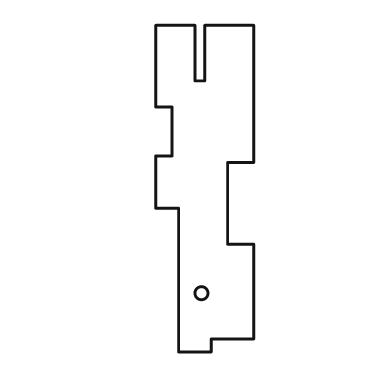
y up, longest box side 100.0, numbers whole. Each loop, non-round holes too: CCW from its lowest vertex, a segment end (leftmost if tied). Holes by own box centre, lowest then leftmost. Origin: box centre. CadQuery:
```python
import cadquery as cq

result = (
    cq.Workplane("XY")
    .moveTo(-8.0, -50.0)
    .lineTo(2.0, -50.0)
    .lineTo(2.0, -46.0)
    .lineTo(15.0, -46.0)
    .lineTo(15.0, -17.0)
    .lineTo(7.0, -17.0)
    .lineTo(7.0, 8.0)
    .lineTo(15.0, 8.0)
    .lineTo(15.0, 50.0)
    .lineTo(0.0, 50.0)
    .lineTo(0.0, 33.0)
    .lineTo(-3.0, 33.0)
    .lineTo(-3.0, 50.0)
    .lineTo(-15.0, 50.0)
    .lineTo(-15.0, 25.0)
    .lineTo(-10.0, 25.0)
    .lineTo(-10.0, 10.0)
    .lineTo(-15.0, 10.0)
    .lineTo(-15.0, -6.0)
    .lineTo(-8.0, -6.0)
    .close()
    .moveTo(-1.0, -32.0)
    .circle(2.0)
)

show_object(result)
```